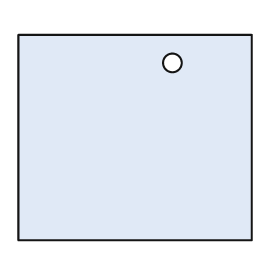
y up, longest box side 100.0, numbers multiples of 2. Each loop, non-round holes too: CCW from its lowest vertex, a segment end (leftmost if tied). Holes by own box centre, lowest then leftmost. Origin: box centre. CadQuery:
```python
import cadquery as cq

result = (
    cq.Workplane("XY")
    .moveTo(-50.0, -44.0)
    .lineTo(50.0, -44.0)
    .lineTo(50.0, 44.0)
    .lineTo(-50.0, 44.0)
    .close()
    .moveTo(16.0, 32.0)
    .circle(4.0)
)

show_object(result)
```